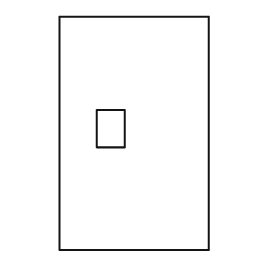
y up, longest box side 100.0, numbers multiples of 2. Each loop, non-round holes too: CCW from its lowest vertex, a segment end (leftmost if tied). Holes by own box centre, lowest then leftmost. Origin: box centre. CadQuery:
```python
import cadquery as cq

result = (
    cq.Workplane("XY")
    .moveTo(-32.0, -50.0)
    .lineTo(32.0, -50.0)
    .lineTo(32.0, 50.0)
    .lineTo(-32.0, 50.0)
    .close()
    .moveTo(-16.0, -6.0)
    .lineTo(-4.0, -6.0)
    .lineTo(-4.0, 10.0)
    .lineTo(-16.0, 10.0)
    .close()
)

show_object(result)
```